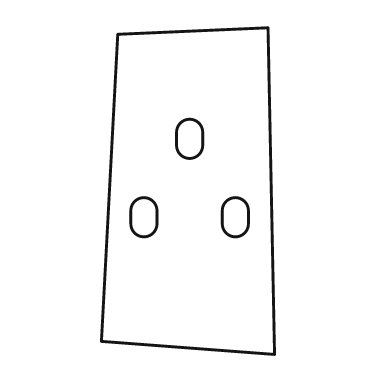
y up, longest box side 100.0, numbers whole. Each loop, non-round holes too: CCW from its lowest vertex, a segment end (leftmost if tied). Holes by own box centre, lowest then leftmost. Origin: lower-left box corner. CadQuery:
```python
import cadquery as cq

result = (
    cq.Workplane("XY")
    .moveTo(53.0, 0.0)
    .lineTo(51.0, 100.0)
    .lineTo(5.0, 98.0)
    .lineTo(0.0, 4.0)
    .close()
    .moveTo(9.0, 40.0)
    .threePointArc((13.0, 36.0), (17.0, 40.0))
    .lineTo(17.0, 44.0)
    .threePointArc((13.0, 48.0), (9.0, 44.0))
    .close()
    .moveTo(37.0, 40.0)
    .threePointArc((41.0, 36.0), (45.0, 40.0))
    .lineTo(45.0, 44.0)
    .threePointArc((41.0, 48.0), (37.0, 44.0))
    .close()
    .moveTo(23.0, 64.0)
    .threePointArc((27.0, 60.0), (31.0, 64.0))
    .lineTo(31.0, 68.0)
    .threePointArc((27.0, 72.0), (23.0, 68.0))
    .close()
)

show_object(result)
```